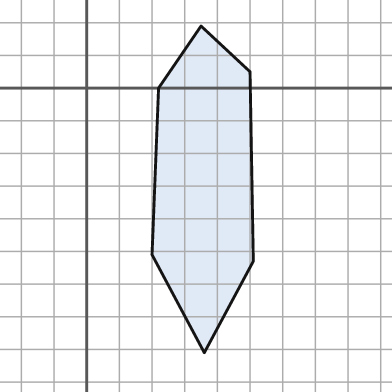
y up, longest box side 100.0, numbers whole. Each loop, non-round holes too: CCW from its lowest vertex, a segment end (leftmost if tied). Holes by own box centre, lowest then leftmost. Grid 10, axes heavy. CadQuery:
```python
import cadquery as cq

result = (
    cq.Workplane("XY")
    .moveTo(36.0, -81.0)
    .lineTo(51.0, -53.0)
    .lineTo(50.0, 5.0)
    .lineTo(35.0, 19.0)
    .lineTo(22.0, 0.0)
    .lineTo(20.0, -51.0)
    .close()
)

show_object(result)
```